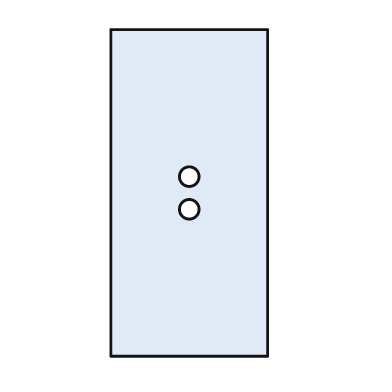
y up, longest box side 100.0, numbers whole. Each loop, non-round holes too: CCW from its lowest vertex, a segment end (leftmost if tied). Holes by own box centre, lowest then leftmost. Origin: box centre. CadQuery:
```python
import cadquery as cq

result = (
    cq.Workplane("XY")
    .moveTo(-24.0, -50.0)
    .lineTo(24.0, -50.0)
    .lineTo(24.0, 50.0)
    .lineTo(-24.0, 50.0)
    .close()
    .moveTo(0.0, -5.0)
    .circle(3.0)
    .moveTo(0.0, 5.0)
    .circle(3.0)
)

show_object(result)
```